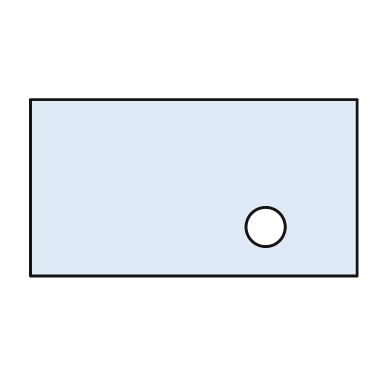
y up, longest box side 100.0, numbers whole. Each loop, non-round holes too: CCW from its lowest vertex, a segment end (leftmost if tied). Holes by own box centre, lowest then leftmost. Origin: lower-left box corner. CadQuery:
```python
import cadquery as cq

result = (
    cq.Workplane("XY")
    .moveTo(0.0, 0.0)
    .lineTo(100.0, 0.0)
    .lineTo(100.0, 54.0)
    .lineTo(0.0, 54.0)
    .close()
    .moveTo(72.0, 15.0)
    .circle(6.0)
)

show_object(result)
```